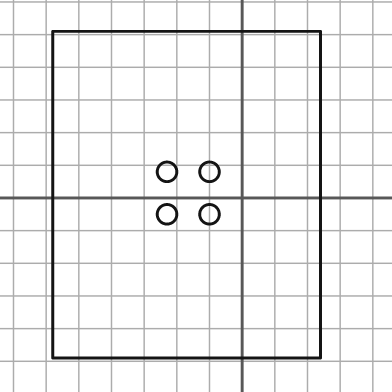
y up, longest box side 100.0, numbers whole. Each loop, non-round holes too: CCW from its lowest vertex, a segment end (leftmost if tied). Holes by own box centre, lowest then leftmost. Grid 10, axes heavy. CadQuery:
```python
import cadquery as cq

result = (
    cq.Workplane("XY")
    .moveTo(-58.0, -49.0)
    .lineTo(24.0, -49.0)
    .lineTo(24.0, 51.0)
    .lineTo(-58.0, 51.0)
    .close()
    .moveTo(-23.0, -5.0)
    .circle(3.0)
    .moveTo(-10.0, -5.0)
    .circle(3.0)
    .moveTo(-23.0, 8.0)
    .circle(3.0)
    .moveTo(-10.0, 8.0)
    .circle(3.0)
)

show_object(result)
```